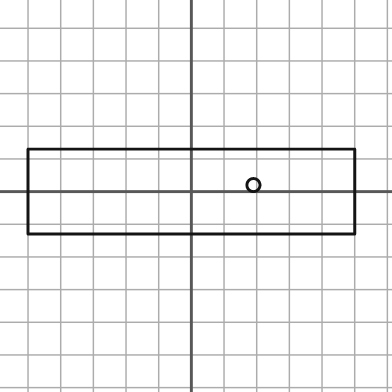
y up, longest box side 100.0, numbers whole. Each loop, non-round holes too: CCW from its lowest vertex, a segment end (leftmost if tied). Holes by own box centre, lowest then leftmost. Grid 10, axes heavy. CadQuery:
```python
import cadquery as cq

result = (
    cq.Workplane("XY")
    .moveTo(-50.0, -13.0)
    .lineTo(50.0, -13.0)
    .lineTo(50.0, 13.0)
    .lineTo(-50.0, 13.0)
    .close()
    .moveTo(19.0, 2.0)
    .circle(2.0)
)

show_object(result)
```